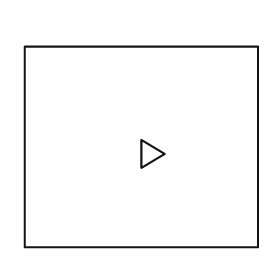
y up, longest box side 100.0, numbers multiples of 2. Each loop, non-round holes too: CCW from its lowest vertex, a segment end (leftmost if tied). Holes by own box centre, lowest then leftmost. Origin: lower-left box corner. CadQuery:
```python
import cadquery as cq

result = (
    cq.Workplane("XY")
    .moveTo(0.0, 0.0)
    .lineTo(100.0, 0.0)
    .lineTo(100.0, 86.0)
    .lineTo(0.0, 86.0)
    .close()
    .moveTo(50.0, 34.0)
    .lineTo(60.0, 40.0)
    .lineTo(50.0, 46.0)
    .close()
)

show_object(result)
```